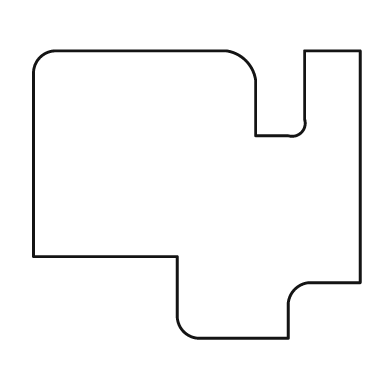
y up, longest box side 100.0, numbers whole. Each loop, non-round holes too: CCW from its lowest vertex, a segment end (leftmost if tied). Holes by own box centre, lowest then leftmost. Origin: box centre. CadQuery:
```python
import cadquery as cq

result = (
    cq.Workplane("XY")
    .moveTo(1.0, -44.0)
    .lineTo(28.0, -44.0)
    .lineTo(28.0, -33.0)
    .threePointArc((30.0, -29.0), (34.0, -27.0))
    .lineTo(50.0, -27.0)
    .lineTo(50.0, 44.0)
    .lineTo(33.0, 44.0)
    .lineTo(33.0, 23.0)
    .threePointArc((32.0, 19.0), (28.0, 18.0))
    .lineTo(18.0, 18.0)
    .lineTo(18.0, 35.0)
    .threePointArc((15.0, 41.0), (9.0, 44.0))
    .lineTo(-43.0, 44.0)
    .threePointArc((-48.0, 42.0), (-50.0, 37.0))
    .lineTo(-50.0, -19.0)
    .lineTo(-6.0, -19.0)
    .lineTo(-6.0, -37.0)
    .threePointArc((-4.0, -42.0), (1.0, -44.0))
    .close()
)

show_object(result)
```